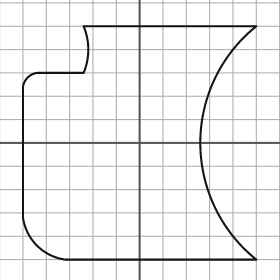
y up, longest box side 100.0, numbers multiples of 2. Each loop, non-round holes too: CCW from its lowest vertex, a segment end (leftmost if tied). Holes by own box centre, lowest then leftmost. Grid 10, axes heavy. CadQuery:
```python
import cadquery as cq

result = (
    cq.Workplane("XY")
    .moveTo(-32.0, -50.0)
    .lineTo(50.0, -50.0)
    .threePointArc((26.0, 0.0), (50.0, 50.0))
    .lineTo(-24.0, 50.0)
    .threePointArc((-22.0, 40.0), (-24.0, 30.0))
    .lineTo(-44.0, 30.0)
    .threePointArc((-48.0, 28.0), (-50.0, 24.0))
    .lineTo(-50.0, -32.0)
    .threePointArc((-44.0, -44.0), (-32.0, -50.0))
    .close()
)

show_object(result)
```